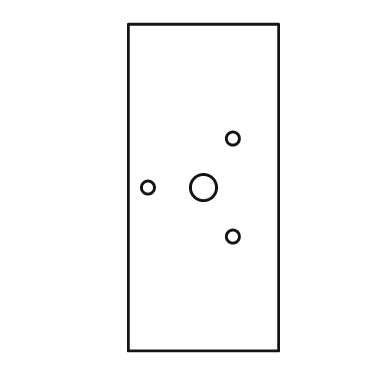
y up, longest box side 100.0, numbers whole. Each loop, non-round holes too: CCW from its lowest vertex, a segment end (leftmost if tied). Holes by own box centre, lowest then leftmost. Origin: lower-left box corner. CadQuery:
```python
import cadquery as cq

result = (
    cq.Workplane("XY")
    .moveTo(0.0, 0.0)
    .lineTo(46.0, 0.0)
    .lineTo(46.0, 100.0)
    .lineTo(0.0, 100.0)
    .close()
    .moveTo(32.0, 35.0)
    .circle(2.0)
    .moveTo(6.0, 50.0)
    .circle(2.0)
    .moveTo(23.0, 50.0)
    .circle(4.0)
    .moveTo(32.0, 65.0)
    .circle(2.0)
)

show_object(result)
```